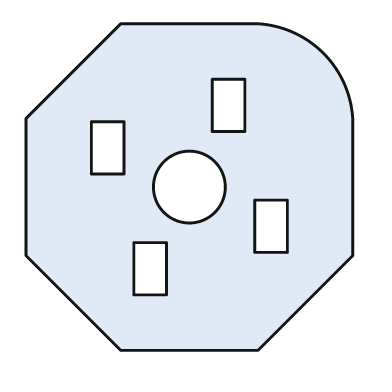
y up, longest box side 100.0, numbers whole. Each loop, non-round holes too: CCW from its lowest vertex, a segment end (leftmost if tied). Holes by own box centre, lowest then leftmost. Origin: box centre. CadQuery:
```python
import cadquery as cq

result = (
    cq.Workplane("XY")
    .moveTo(-21.0, -50.0)
    .lineTo(21.0, -50.0)
    .lineTo(50.0, -21.0)
    .lineTo(50.0, 21.0)
    .threePointArc((41.0, 41.0), (21.0, 50.0))
    .lineTo(-21.0, 50.0)
    .lineTo(-50.0, 21.0)
    .lineTo(-50.0, -21.0)
    .close()
    .moveTo(-17.0, -33.0)
    .lineTo(-7.0, -33.0)
    .lineTo(-7.0, -17.0)
    .lineTo(-17.0, -17.0)
    .close()
    .moveTo(20.0, -20.0)
    .lineTo(30.0, -20.0)
    .lineTo(30.0, -4.0)
    .lineTo(20.0, -4.0)
    .close()
    .moveTo(0.0, 0.0)
    .circle(11.0)
    .moveTo(-30.0, 4.0)
    .lineTo(-20.0, 4.0)
    .lineTo(-20.0, 20.0)
    .lineTo(-30.0, 20.0)
    .close()
    .moveTo(7.0, 17.0)
    .lineTo(17.0, 17.0)
    .lineTo(17.0, 33.0)
    .lineTo(7.0, 33.0)
    .close()
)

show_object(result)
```